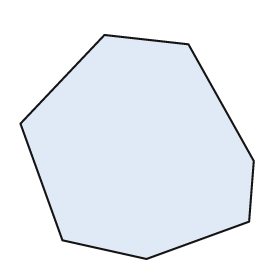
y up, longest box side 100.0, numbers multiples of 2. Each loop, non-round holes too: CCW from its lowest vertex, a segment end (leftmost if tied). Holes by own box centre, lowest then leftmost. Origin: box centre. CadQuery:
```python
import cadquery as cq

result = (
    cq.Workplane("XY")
    .moveTo(4.0, -48.0)
    .lineTo(48.0, -32.0)
    .lineTo(50.0, -6.0)
    .lineTo(22.0, 44.0)
    .lineTo(-14.0, 48.0)
    .lineTo(-50.0, 10.0)
    .lineTo(-32.0, -40.0)
    .close()
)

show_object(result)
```